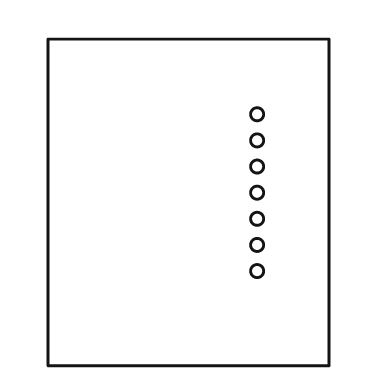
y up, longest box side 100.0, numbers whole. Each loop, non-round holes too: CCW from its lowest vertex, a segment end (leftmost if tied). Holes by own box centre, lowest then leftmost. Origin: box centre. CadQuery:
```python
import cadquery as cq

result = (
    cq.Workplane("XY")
    .moveTo(-43.0, -50.0)
    .lineTo(43.0, -50.0)
    .lineTo(43.0, 50.0)
    .lineTo(-43.0, 50.0)
    .close()
    .moveTo(21.0, -21.0)
    .circle(2.0)
    .moveTo(21.0, -13.0)
    .circle(2.0)
    .moveTo(21.0, -5.0)
    .circle(2.0)
    .moveTo(21.0, 3.0)
    .circle(2.0)
    .moveTo(21.0, 11.0)
    .circle(2.0)
    .moveTo(21.0, 19.0)
    .circle(2.0)
    .moveTo(21.0, 27.0)
    .circle(2.0)
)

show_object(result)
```